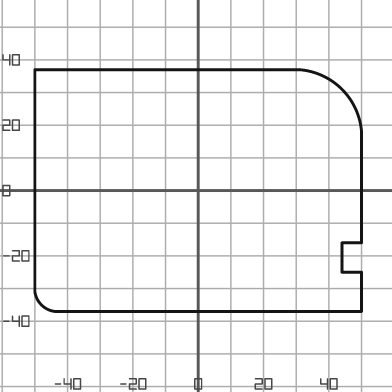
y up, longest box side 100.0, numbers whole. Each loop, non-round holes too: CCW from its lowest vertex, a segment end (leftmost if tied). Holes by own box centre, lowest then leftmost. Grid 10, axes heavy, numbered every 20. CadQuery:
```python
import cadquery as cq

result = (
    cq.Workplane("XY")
    .moveTo(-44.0, -37.0)
    .lineTo(50.0, -37.0)
    .lineTo(50.0, -25.0)
    .lineTo(44.0, -25.0)
    .lineTo(44.0, -16.0)
    .lineTo(50.0, -16.0)
    .lineTo(50.0, 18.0)
    .threePointArc((44.0, 31.0), (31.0, 37.0))
    .lineTo(-50.0, 37.0)
    .lineTo(-50.0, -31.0)
    .threePointArc((-48.0, -35.0), (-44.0, -37.0))
    .close()
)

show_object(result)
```